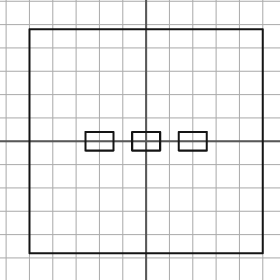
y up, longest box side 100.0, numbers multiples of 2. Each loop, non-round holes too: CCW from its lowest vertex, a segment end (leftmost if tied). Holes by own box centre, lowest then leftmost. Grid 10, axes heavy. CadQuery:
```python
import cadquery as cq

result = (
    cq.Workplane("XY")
    .moveTo(-50.0, -48.0)
    .lineTo(50.0, -48.0)
    .lineTo(50.0, 48.0)
    .lineTo(-50.0, 48.0)
    .close()
    .moveTo(-26.0, -4.0)
    .lineTo(-14.0, -4.0)
    .lineTo(-14.0, 4.0)
    .lineTo(-26.0, 4.0)
    .close()
    .moveTo(-6.0, -4.0)
    .lineTo(6.0, -4.0)
    .lineTo(6.0, 4.0)
    .lineTo(-6.0, 4.0)
    .close()
    .moveTo(14.0, -4.0)
    .lineTo(26.0, -4.0)
    .lineTo(26.0, 4.0)
    .lineTo(14.0, 4.0)
    .close()
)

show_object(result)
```